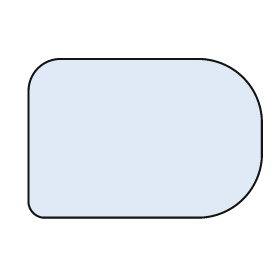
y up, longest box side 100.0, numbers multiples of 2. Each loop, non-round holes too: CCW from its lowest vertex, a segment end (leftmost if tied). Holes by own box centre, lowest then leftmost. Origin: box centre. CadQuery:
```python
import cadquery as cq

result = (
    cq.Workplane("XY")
    .moveTo(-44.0, -34.0)
    .lineTo(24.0, -34.0)
    .threePointArc((42.0, -26.0), (50.0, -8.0))
    .lineTo(50.0, 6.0)
    .threePointArc((42.0, 26.0), (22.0, 34.0))
    .lineTo(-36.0, 34.0)
    .threePointArc((-46.0, 30.0), (-50.0, 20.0))
    .lineTo(-50.0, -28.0)
    .threePointArc((-48.0, -32.0), (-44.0, -34.0))
    .close()
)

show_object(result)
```